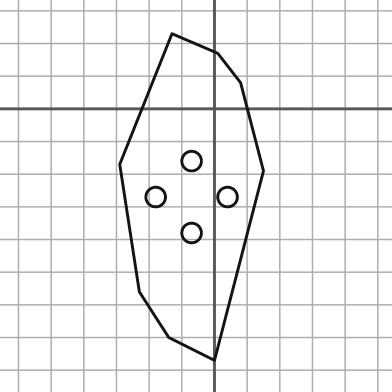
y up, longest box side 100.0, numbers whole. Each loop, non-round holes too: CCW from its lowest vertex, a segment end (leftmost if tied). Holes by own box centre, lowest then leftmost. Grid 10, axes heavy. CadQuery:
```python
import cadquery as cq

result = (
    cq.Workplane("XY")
    .moveTo(0.0, -77.0)
    .lineTo(15.0, -19.0)
    .lineTo(8.0, 8.0)
    .lineTo(1.0, 17.0)
    .lineTo(-13.0, 23.0)
    .lineTo(-29.0, -17.0)
    .lineTo(-23.0, -56.0)
    .lineTo(-14.0, -70.0)
    .close()
    .moveTo(-7.0, -38.0)
    .circle(3.0)
    .moveTo(-18.0, -27.0)
    .circle(3.0)
    .moveTo(4.0, -27.0)
    .circle(3.0)
    .moveTo(-7.0, -16.0)
    .circle(3.0)
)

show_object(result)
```